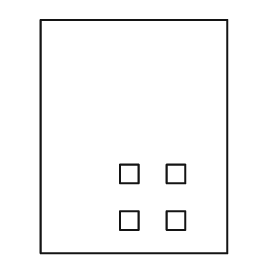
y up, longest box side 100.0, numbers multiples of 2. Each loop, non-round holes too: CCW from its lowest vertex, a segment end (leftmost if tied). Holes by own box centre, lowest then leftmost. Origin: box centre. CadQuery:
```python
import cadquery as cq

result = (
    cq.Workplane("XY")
    .moveTo(-40.0, -50.0)
    .lineTo(40.0, -50.0)
    .lineTo(40.0, 50.0)
    .lineTo(-40.0, 50.0)
    .close()
    .moveTo(-6.0, -40.0)
    .lineTo(2.0, -40.0)
    .lineTo(2.0, -32.0)
    .lineTo(-6.0, -32.0)
    .close()
    .moveTo(14.0, -40.0)
    .lineTo(22.0, -40.0)
    .lineTo(22.0, -32.0)
    .lineTo(14.0, -32.0)
    .close()
    .moveTo(-6.0, -20.0)
    .lineTo(2.0, -20.0)
    .lineTo(2.0, -12.0)
    .lineTo(-6.0, -12.0)
    .close()
    .moveTo(14.0, -20.0)
    .lineTo(22.0, -20.0)
    .lineTo(22.0, -12.0)
    .lineTo(14.0, -12.0)
    .close()
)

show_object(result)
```